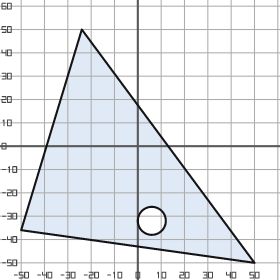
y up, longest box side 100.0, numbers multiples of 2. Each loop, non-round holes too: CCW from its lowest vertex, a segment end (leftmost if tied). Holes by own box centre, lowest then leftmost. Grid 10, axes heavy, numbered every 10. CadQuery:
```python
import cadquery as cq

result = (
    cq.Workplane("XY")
    .moveTo(50.0, -50.0)
    .lineTo(-24.0, 50.0)
    .lineTo(-50.0, -36.0)
    .close()
    .moveTo(6.0, -32.0)
    .circle(6.0)
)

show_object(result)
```